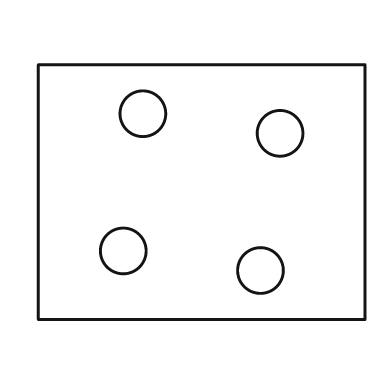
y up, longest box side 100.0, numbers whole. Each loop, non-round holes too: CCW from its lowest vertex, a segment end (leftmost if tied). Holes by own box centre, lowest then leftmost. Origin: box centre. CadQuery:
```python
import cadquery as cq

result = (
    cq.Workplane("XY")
    .moveTo(-50.0, -39.0)
    .lineTo(50.0, -39.0)
    .lineTo(50.0, 39.0)
    .lineTo(-50.0, 39.0)
    .close()
    .moveTo(18.0, -24.0)
    .circle(7.0)
    .moveTo(-24.0, -18.0)
    .circle(7.0)
    .moveTo(24.0, 18.0)
    .circle(7.0)
    .moveTo(-18.0, 24.0)
    .circle(7.0)
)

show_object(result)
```